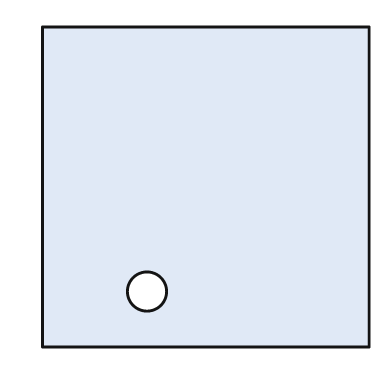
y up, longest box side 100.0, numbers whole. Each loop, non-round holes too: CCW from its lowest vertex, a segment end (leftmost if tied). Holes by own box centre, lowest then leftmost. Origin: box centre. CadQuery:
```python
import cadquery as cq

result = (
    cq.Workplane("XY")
    .moveTo(-50.0, -49.0)
    .lineTo(50.0, -49.0)
    .lineTo(50.0, 49.0)
    .lineTo(-50.0, 49.0)
    .close()
    .moveTo(-18.0, -32.0)
    .circle(6.0)
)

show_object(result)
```